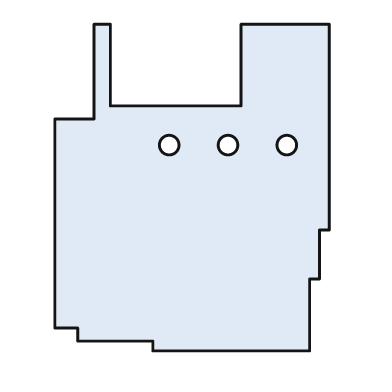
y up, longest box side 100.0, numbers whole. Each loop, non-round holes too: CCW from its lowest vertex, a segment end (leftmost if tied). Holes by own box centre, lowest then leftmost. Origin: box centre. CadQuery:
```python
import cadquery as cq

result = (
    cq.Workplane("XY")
    .moveTo(-12.0, -50.0)
    .lineTo(36.0, -50.0)
    .lineTo(36.0, -28.0)
    .lineTo(39.0, -28.0)
    .lineTo(39.0, -13.0)
    .lineTo(42.0, -13.0)
    .lineTo(42.0, 50.0)
    .lineTo(15.0, 50.0)
    .lineTo(15.0, 25.0)
    .lineTo(-25.0, 25.0)
    .lineTo(-25.0, 50.0)
    .lineTo(-30.0, 50.0)
    .lineTo(-30.0, 21.0)
    .lineTo(-42.0, 21.0)
    .lineTo(-42.0, -43.0)
    .lineTo(-35.0, -43.0)
    .lineTo(-35.0, -47.0)
    .lineTo(-12.0, -47.0)
    .close()
    .moveTo(-7.0, 13.0)
    .circle(3.0)
    .moveTo(11.0, 13.0)
    .circle(3.0)
    .moveTo(29.0, 13.0)
    .circle(3.0)
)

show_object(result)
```